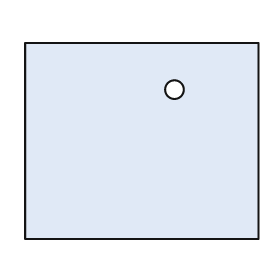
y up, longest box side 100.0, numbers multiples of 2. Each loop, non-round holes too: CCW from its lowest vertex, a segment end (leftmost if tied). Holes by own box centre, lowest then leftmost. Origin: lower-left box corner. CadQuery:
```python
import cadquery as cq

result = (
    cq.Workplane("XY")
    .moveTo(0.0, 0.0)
    .lineTo(100.0, 0.0)
    .lineTo(100.0, 84.0)
    .lineTo(0.0, 84.0)
    .close()
    .moveTo(64.0, 64.0)
    .circle(4.0)
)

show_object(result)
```